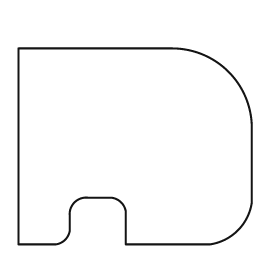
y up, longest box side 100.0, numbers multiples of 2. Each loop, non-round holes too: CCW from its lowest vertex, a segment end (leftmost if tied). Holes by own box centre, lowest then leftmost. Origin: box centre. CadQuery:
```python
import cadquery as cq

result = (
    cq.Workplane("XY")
    .moveTo(-50.0, -42.0)
    .lineTo(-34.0, -42.0)
    .threePointArc((-30.0, -40.0), (-28.0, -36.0))
    .lineTo(-28.0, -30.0)
    .threePointArc((-26.0, -24.0), (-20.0, -22.0))
    .lineTo(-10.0, -22.0)
    .threePointArc((-6.0, -24.0), (-4.0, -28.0))
    .lineTo(-4.0, -42.0)
    .lineTo(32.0, -42.0)
    .threePointArc((44.0, -36.0), (50.0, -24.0))
    .lineTo(50.0, 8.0)
    .threePointArc((40.0, 32.0), (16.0, 42.0))
    .lineTo(-50.0, 42.0)
    .close()
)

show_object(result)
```